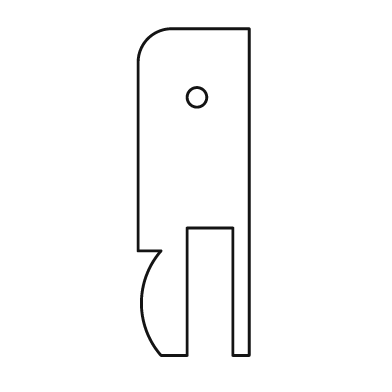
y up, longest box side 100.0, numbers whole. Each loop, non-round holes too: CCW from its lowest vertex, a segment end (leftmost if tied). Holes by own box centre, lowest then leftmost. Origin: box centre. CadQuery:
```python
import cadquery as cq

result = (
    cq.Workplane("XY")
    .moveTo(-10.0, -50.0)
    .lineTo(-2.0, -50.0)
    .lineTo(-2.0, -11.0)
    .lineTo(12.0, -11.0)
    .lineTo(12.0, -50.0)
    .lineTo(17.0, -50.0)
    .lineTo(17.0, 50.0)
    .lineTo(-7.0, 50.0)
    .threePointArc((-14.0, 47.0), (-17.0, 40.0))
    .lineTo(-17.0, -18.0)
    .lineTo(-10.0, -18.0)
    .threePointArc((-16.0, -34.0), (-10.0, -50.0))
    .close()
    .moveTo(1.0, 29.0)
    .circle(3.0)
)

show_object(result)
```